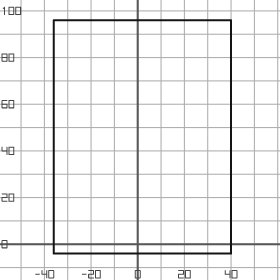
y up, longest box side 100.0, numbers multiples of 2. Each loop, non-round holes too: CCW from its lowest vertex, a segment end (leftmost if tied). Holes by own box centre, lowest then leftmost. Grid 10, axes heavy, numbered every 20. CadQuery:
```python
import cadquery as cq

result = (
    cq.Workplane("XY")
    .moveTo(-36.0, -4.0)
    .lineTo(40.0, -4.0)
    .lineTo(40.0, 96.0)
    .lineTo(-36.0, 96.0)
    .close()
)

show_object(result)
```